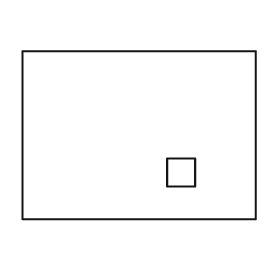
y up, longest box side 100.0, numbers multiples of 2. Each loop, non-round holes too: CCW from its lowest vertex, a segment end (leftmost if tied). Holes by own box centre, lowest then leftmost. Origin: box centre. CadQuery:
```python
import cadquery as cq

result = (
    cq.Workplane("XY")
    .moveTo(-50.0, -36.0)
    .lineTo(50.0, -36.0)
    .lineTo(50.0, 36.0)
    .lineTo(-50.0, 36.0)
    .close()
    .moveTo(12.0, -22.0)
    .lineTo(24.0, -22.0)
    .lineTo(24.0, -10.0)
    .lineTo(12.0, -10.0)
    .close()
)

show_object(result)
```